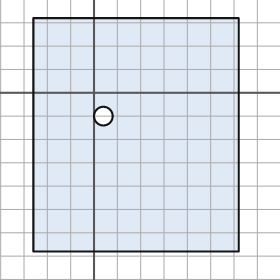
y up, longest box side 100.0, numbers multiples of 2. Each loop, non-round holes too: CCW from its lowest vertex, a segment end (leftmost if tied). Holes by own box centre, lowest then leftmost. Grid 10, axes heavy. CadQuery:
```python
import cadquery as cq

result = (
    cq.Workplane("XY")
    .moveTo(-26.0, -68.0)
    .lineTo(62.0, -68.0)
    .lineTo(62.0, 32.0)
    .lineTo(-26.0, 32.0)
    .close()
    .moveTo(4.0, -10.0)
    .circle(4.0)
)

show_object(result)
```